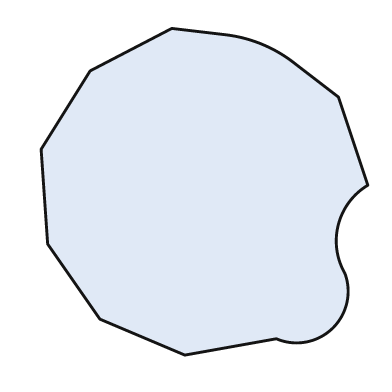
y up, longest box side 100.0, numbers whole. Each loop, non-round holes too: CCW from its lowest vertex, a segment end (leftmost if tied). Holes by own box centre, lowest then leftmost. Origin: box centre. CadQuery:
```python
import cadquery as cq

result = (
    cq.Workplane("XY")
    .moveTo(-6.0, -50.0)
    .lineTo(22.0, -45.0)
    .threePointArc((39.0, -42.0), (43.0, -25.0))
    .threePointArc((41.0, -10.0), (50.0, 2.0))
    .lineTo(41.0, 29.0)
    .lineTo(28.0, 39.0)
    .threePointArc((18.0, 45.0), (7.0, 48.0))
    .lineTo(-10.0, 50.0)
    .lineTo(-35.0, 37.0)
    .lineTo(-50.0, 13.0)
    .lineTo(-48.0, -16.0)
    .lineTo(-32.0, -39.0)
    .close()
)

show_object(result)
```